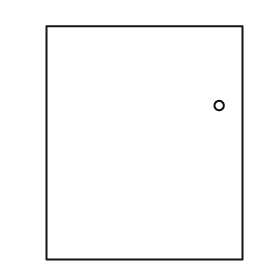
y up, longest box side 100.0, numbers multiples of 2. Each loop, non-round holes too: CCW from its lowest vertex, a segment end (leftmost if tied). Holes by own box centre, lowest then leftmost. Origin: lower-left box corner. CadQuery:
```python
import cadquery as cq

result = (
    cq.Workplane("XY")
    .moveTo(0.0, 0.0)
    .lineTo(84.0, 0.0)
    .lineTo(84.0, 100.0)
    .lineTo(0.0, 100.0)
    .close()
    .moveTo(74.0, 66.0)
    .circle(2.0)
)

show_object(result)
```